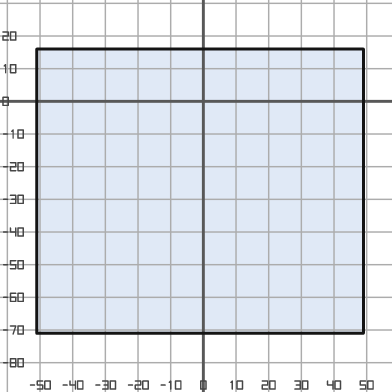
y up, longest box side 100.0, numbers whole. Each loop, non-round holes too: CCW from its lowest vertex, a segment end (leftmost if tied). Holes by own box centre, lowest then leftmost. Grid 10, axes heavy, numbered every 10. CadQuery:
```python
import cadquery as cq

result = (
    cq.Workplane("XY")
    .moveTo(-51.0, -71.0)
    .lineTo(49.0, -71.0)
    .lineTo(49.0, 16.0)
    .lineTo(-51.0, 16.0)
    .close()
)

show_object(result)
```